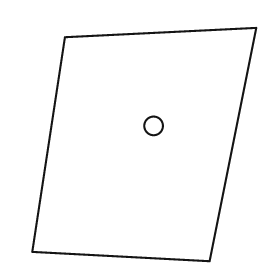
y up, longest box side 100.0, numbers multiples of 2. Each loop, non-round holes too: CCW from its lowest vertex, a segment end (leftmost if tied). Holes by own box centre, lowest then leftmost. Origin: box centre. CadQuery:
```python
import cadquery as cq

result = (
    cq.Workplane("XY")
    .moveTo(28.0, -50.0)
    .lineTo(48.0, 50.0)
    .lineTo(-34.0, 46.0)
    .lineTo(-48.0, -46.0)
    .close()
    .moveTo(4.0, 8.0)
    .circle(4.0)
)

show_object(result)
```